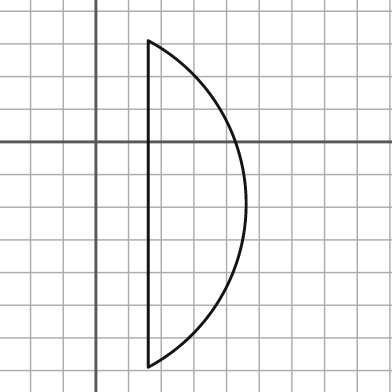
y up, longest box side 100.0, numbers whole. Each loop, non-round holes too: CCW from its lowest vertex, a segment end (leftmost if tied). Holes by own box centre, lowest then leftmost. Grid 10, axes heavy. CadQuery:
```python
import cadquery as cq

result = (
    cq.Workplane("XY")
    .moveTo(16.0, -69.0)
    .threePointArc((46.0, -19.0), (16.0, 31.0))
    .close()
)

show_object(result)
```